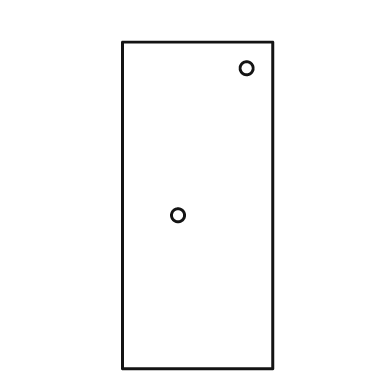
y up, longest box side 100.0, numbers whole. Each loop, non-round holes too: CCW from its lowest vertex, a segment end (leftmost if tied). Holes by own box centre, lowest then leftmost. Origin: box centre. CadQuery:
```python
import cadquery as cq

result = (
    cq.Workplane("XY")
    .moveTo(-23.0, -50.0)
    .lineTo(23.0, -50.0)
    .lineTo(23.0, 50.0)
    .lineTo(-23.0, 50.0)
    .close()
    .moveTo(-6.0, -3.0)
    .circle(2.0)
    .moveTo(15.0, 42.0)
    .circle(2.0)
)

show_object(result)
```